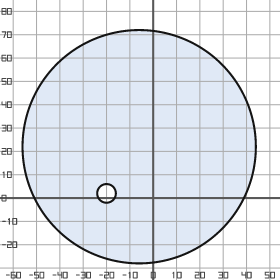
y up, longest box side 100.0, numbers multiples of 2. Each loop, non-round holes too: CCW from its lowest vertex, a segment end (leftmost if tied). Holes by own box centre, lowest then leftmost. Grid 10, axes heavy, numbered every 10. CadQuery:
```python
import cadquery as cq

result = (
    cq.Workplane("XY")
    .moveTo(-6.0, 22.0)
    .circle(50.0)
    .moveTo(-20.0, 2.0)
    .circle(4.0)
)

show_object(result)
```